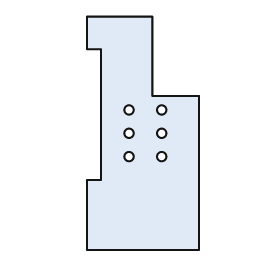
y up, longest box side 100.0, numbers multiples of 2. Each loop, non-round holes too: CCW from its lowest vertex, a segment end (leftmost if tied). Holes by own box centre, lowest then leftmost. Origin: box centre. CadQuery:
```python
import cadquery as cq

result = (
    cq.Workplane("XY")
    .moveTo(-24.0, -50.0)
    .lineTo(24.0, -50.0)
    .lineTo(24.0, 16.0)
    .lineTo(4.0, 16.0)
    .lineTo(4.0, 50.0)
    .lineTo(-24.0, 50.0)
    .lineTo(-24.0, 36.0)
    .lineTo(-18.0, 36.0)
    .lineTo(-18.0, -20.0)
    .lineTo(-24.0, -20.0)
    .close()
    .moveTo(-6.0, -10.0)
    .circle(2.0)
    .moveTo(8.0, -10.0)
    .circle(2.0)
    .moveTo(-6.0, 0.0)
    .circle(2.0)
    .moveTo(8.0, 0.0)
    .circle(2.0)
    .moveTo(-6.0, 10.0)
    .circle(2.0)
    .moveTo(8.0, 10.0)
    .circle(2.0)
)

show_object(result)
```